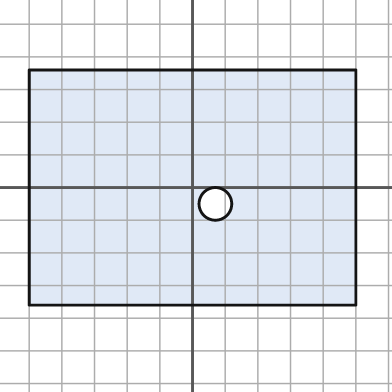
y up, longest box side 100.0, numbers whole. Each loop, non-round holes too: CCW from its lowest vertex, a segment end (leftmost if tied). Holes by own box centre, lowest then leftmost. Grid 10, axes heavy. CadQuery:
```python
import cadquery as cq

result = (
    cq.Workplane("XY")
    .moveTo(-50.0, -36.0)
    .lineTo(50.0, -36.0)
    .lineTo(50.0, 36.0)
    .lineTo(-50.0, 36.0)
    .close()
    .moveTo(7.0, -5.0)
    .circle(5.0)
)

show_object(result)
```